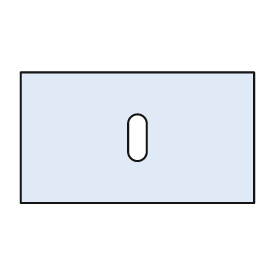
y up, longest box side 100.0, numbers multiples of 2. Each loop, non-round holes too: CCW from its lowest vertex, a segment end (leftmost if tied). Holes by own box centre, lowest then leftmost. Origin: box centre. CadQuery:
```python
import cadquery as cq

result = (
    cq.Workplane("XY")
    .moveTo(-50.0, -28.0)
    .lineTo(50.0, -28.0)
    .lineTo(50.0, 28.0)
    .lineTo(-50.0, 28.0)
    .close()
    .moveTo(-4.0, -6.0)
    .threePointArc((0.0, -10.0), (4.0, -6.0))
    .lineTo(4.0, 6.0)
    .threePointArc((0.0, 10.0), (-4.0, 6.0))
    .close()
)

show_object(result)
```